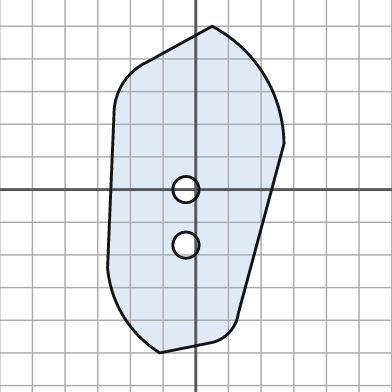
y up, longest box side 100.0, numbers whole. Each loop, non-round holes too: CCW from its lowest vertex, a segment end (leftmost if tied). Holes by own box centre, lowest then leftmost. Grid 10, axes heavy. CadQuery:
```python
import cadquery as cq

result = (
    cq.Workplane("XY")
    .moveTo(-11.0, -50.0)
    .lineTo(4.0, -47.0)
    .threePointArc((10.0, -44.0), (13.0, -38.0))
    .lineTo(27.0, 14.0)
    .threePointArc((21.0, 35.0), (5.0, 50.0))
    .lineTo(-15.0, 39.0)
    .threePointArc((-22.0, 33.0), (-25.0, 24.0))
    .lineTo(-27.0, -24.0)
    .threePointArc((-22.0, -39.0), (-11.0, -50.0))
    .close()
    .moveTo(-3.0, -17.0)
    .circle(4.0)
    .moveTo(-3.0, 0.0)
    .circle(4.0)
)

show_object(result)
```